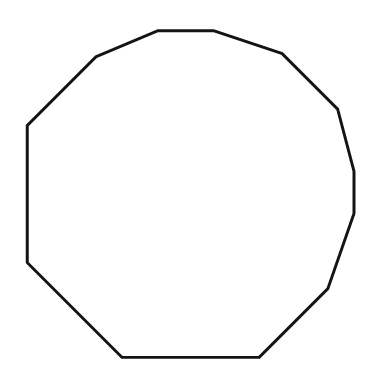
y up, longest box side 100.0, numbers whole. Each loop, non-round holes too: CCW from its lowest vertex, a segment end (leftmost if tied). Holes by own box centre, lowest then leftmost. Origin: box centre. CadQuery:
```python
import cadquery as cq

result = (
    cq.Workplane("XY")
    .moveTo(-21.0, -50.0)
    .lineTo(21.0, -50.0)
    .lineTo(42.0, -29.0)
    .lineTo(50.0, -6.0)
    .lineTo(50.0, 7.0)
    .lineTo(45.0, 26.0)
    .lineTo(28.0, 43.0)
    .lineTo(7.0, 50.0)
    .lineTo(-10.0, 50.0)
    .lineTo(-29.0, 42.0)
    .lineTo(-50.0, 21.0)
    .lineTo(-50.0, -21.0)
    .close()
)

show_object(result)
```